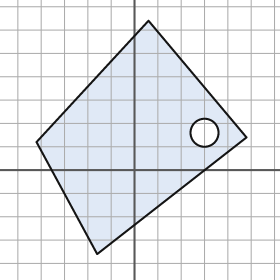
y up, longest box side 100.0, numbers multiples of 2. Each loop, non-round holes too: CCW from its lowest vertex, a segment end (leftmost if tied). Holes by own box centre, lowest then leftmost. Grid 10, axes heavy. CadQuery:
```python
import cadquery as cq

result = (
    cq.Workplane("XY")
    .moveTo(-16.0, -36.0)
    .lineTo(48.0, 14.0)
    .lineTo(6.0, 64.0)
    .lineTo(-42.0, 12.0)
    .close()
    .moveTo(30.0, 16.0)
    .circle(6.0)
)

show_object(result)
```